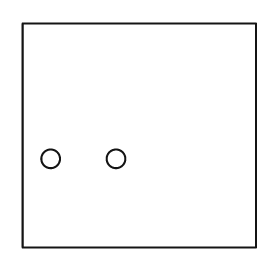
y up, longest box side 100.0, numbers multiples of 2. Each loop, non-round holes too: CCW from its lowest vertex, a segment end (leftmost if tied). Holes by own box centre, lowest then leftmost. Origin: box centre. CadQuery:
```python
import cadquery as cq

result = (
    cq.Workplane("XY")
    .moveTo(-50.0, -48.0)
    .lineTo(50.0, -48.0)
    .lineTo(50.0, 48.0)
    .lineTo(-50.0, 48.0)
    .close()
    .moveTo(-38.0, -10.0)
    .circle(4.0)
    .moveTo(-10.0, -10.0)
    .circle(4.0)
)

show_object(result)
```